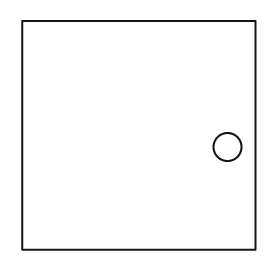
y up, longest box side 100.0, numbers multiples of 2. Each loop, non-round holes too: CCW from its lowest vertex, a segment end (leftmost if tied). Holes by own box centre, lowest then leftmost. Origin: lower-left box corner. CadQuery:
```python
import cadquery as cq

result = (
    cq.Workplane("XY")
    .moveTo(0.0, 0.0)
    .lineTo(100.0, 0.0)
    .lineTo(100.0, 98.0)
    .lineTo(0.0, 98.0)
    .close()
    .moveTo(88.0, 44.0)
    .circle(6.0)
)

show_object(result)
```